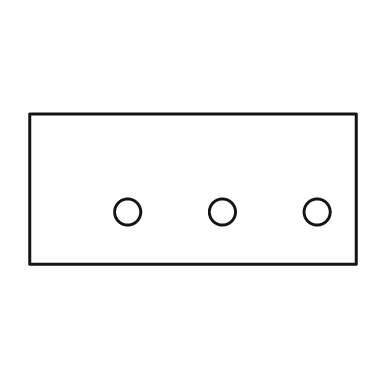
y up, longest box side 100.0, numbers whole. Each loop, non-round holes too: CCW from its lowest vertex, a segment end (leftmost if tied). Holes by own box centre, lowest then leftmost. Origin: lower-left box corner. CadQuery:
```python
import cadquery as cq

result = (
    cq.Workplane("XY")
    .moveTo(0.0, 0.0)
    .lineTo(100.0, 0.0)
    .lineTo(100.0, 46.0)
    .lineTo(0.0, 46.0)
    .close()
    .moveTo(30.0, 16.0)
    .circle(4.0)
    .moveTo(59.0, 16.0)
    .circle(4.0)
    .moveTo(88.0, 16.0)
    .circle(4.0)
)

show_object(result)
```